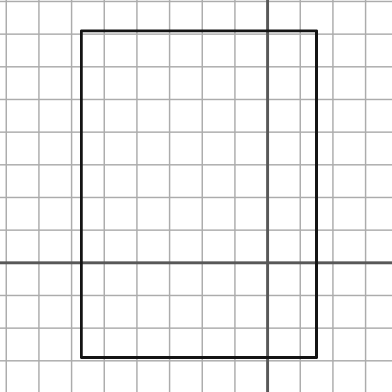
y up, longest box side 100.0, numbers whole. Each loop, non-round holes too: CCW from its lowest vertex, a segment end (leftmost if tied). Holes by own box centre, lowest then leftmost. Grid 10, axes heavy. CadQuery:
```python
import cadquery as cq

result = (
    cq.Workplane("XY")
    .moveTo(-57.0, -29.0)
    .lineTo(15.0, -29.0)
    .lineTo(15.0, 71.0)
    .lineTo(-57.0, 71.0)
    .close()
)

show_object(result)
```